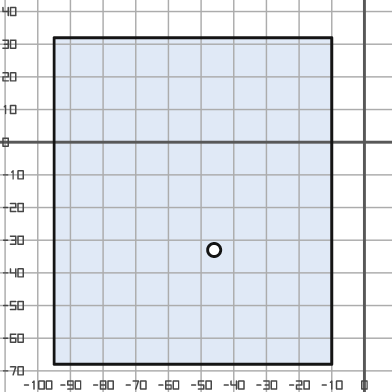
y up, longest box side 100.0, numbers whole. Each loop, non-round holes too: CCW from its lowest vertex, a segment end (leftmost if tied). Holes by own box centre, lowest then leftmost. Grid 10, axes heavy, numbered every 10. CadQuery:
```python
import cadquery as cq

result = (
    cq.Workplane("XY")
    .moveTo(-95.0, -68.0)
    .lineTo(-10.0, -68.0)
    .lineTo(-10.0, 32.0)
    .lineTo(-95.0, 32.0)
    .close()
    .moveTo(-46.0, -33.0)
    .circle(2.0)
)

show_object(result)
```